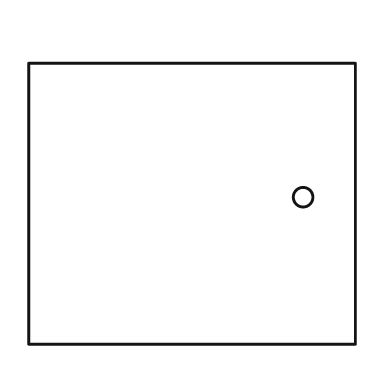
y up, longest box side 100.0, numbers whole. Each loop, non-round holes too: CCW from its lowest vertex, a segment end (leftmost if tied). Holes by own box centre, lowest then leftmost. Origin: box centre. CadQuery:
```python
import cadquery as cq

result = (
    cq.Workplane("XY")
    .moveTo(-50.0, -43.0)
    .lineTo(50.0, -43.0)
    .lineTo(50.0, 43.0)
    .lineTo(-50.0, 43.0)
    .close()
    .moveTo(34.0, 2.0)
    .circle(3.0)
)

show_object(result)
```